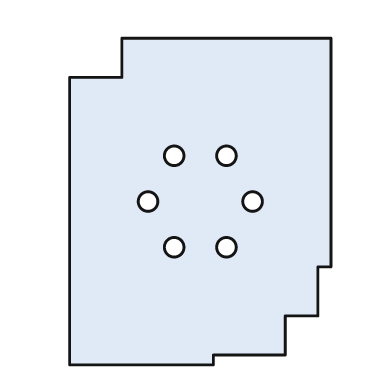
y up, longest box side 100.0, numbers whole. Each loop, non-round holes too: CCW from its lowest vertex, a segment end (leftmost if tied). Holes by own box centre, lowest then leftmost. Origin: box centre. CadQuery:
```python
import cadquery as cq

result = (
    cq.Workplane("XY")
    .moveTo(-40.0, -50.0)
    .lineTo(4.0, -50.0)
    .lineTo(4.0, -47.0)
    .lineTo(26.0, -47.0)
    .lineTo(26.0, -35.0)
    .lineTo(36.0, -35.0)
    .lineTo(36.0, -20.0)
    .lineTo(40.0, -20.0)
    .lineTo(40.0, 50.0)
    .lineTo(-24.0, 50.0)
    .lineTo(-24.0, 38.0)
    .lineTo(-40.0, 38.0)
    .close()
    .moveTo(-8.0, -14.0)
    .circle(3.0)
    .moveTo(8.0, -14.0)
    .circle(3.0)
    .moveTo(-16.0, 0.0)
    .circle(3.0)
    .moveTo(16.0, 0.0)
    .circle(3.0)
    .moveTo(-8.0, 14.0)
    .circle(3.0)
    .moveTo(8.0, 14.0)
    .circle(3.0)
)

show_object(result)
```